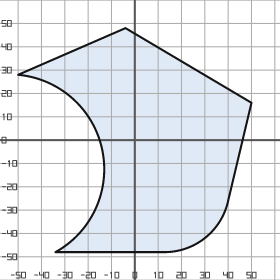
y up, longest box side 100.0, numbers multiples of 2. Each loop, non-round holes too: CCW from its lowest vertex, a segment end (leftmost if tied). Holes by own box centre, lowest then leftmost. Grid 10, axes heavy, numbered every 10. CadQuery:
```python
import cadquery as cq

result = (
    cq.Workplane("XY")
    .moveTo(-34.0, -48.0)
    .lineTo(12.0, -48.0)
    .threePointArc((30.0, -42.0), (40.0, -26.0))
    .lineTo(50.0, 16.0)
    .lineTo(-4.0, 48.0)
    .lineTo(-50.0, 28.0)
    .threePointArc((-14.0, -4.0), (-34.0, -48.0))
    .close()
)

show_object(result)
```